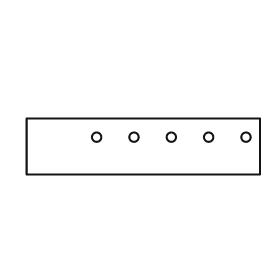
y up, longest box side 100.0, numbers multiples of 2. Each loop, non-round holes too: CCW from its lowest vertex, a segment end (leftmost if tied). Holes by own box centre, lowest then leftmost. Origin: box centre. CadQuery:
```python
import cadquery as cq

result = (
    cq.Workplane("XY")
    .moveTo(-50.0, -12.0)
    .lineTo(50.0, -12.0)
    .lineTo(50.0, 12.0)
    .lineTo(-50.0, 12.0)
    .close()
    .moveTo(-20.0, 4.0)
    .circle(2.0)
    .moveTo(-4.0, 4.0)
    .circle(2.0)
    .moveTo(12.0, 4.0)
    .circle(2.0)
    .moveTo(28.0, 4.0)
    .circle(2.0)
    .moveTo(44.0, 4.0)
    .circle(2.0)
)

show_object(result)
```